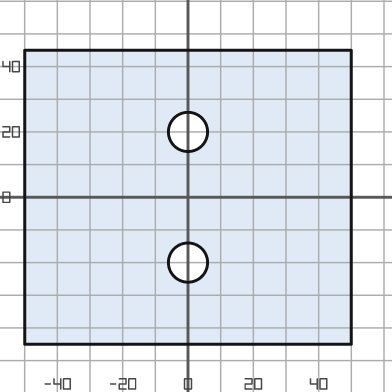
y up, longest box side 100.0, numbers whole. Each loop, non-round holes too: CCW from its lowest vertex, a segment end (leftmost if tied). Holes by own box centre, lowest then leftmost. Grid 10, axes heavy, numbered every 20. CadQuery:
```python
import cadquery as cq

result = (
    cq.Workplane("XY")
    .moveTo(-50.0, -45.0)
    .lineTo(50.0, -45.0)
    .lineTo(50.0, 45.0)
    .lineTo(-50.0, 45.0)
    .close()
    .moveTo(0.0, -20.0)
    .circle(6.0)
    .moveTo(0.0, 20.0)
    .circle(6.0)
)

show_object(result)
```